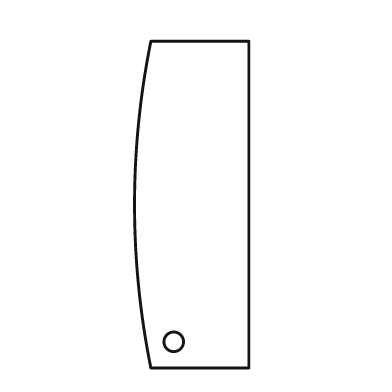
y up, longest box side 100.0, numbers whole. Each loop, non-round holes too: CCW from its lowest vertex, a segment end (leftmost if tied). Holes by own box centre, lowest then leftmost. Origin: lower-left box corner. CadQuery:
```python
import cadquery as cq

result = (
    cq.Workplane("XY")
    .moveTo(5.0, 0.0)
    .lineTo(35.0, 0.0)
    .lineTo(35.0, 100.0)
    .lineTo(5.0, 100.0)
    .threePointArc((0.0, 50.0), (5.0, 0.0))
    .close()
    .moveTo(12.0, 8.0)
    .circle(3.0)
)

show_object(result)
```